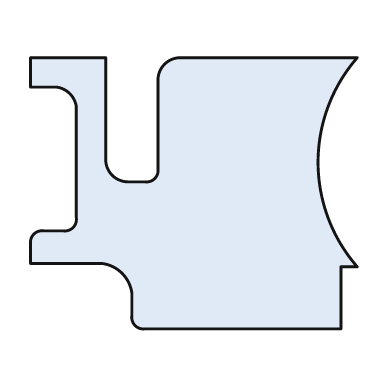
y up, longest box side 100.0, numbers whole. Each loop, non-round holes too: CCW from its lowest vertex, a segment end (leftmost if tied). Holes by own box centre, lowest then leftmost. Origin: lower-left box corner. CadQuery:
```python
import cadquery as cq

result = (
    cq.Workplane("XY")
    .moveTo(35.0, 0.0)
    .lineTo(95.0, 0.0)
    .lineTo(95.0, 19.0)
    .lineTo(100.0, 19.0)
    .threePointArc((88.0, 51.0), (100.0, 83.0))
    .lineTo(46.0, 83.0)
    .threePointArc((41.0, 81.0), (39.0, 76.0))
    .lineTo(39.0, 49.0)
    .threePointArc((38.0, 46.0), (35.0, 45.0))
    .lineTo(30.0, 45.0)
    .threePointArc((25.0, 47.0), (23.0, 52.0))
    .lineTo(23.0, 83.0)
    .lineTo(0.0, 83.0)
    .lineTo(0.0, 74.0)
    .lineTo(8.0, 74.0)
    .threePointArc((12.0, 72.0), (14.0, 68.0))
    .lineTo(14.0, 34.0)
    .threePointArc((13.0, 31.0), (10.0, 30.0))
    .lineTo(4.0, 30.0)
    .threePointArc((1.0, 29.0), (0.0, 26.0))
    .lineTo(0.0, 20.0)
    .lineTo(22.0, 20.0)
    .threePointArc((28.0, 17.0), (31.0, 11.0))
    .lineTo(31.0, 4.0)
    .threePointArc((32.0, 1.0), (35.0, 0.0))
    .close()
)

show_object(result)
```